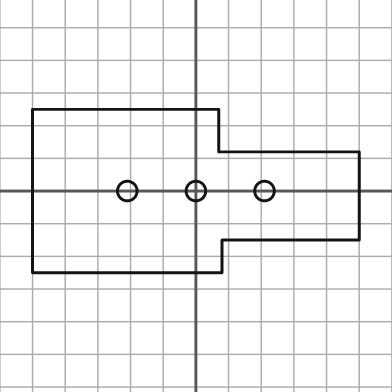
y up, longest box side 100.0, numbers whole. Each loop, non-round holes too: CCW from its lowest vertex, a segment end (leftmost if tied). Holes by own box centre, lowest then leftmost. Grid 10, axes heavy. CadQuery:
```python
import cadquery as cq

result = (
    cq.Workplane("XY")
    .moveTo(-50.0, -25.0)
    .lineTo(8.0, -25.0)
    .lineTo(8.0, -15.0)
    .lineTo(50.0, -15.0)
    .lineTo(50.0, 12.0)
    .lineTo(7.0, 12.0)
    .lineTo(7.0, 25.0)
    .lineTo(-50.0, 25.0)
    .close()
    .moveTo(-21.0, 0.0)
    .circle(3.0)
    .moveTo(0.0, 0.0)
    .circle(3.0)
    .moveTo(21.0, 0.0)
    .circle(3.0)
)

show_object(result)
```